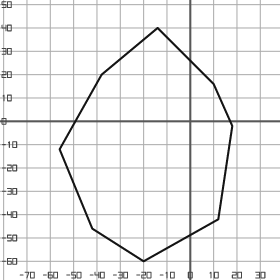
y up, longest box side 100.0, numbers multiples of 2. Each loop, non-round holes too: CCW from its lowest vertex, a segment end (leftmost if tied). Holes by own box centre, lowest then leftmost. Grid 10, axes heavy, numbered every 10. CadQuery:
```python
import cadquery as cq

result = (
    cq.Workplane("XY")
    .moveTo(-20.0, -60.0)
    .lineTo(12.0, -42.0)
    .lineTo(18.0, -2.0)
    .lineTo(10.0, 16.0)
    .lineTo(-14.0, 40.0)
    .lineTo(-38.0, 20.0)
    .lineTo(-56.0, -12.0)
    .lineTo(-42.0, -46.0)
    .close()
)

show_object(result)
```